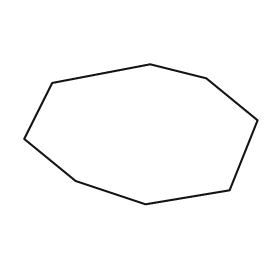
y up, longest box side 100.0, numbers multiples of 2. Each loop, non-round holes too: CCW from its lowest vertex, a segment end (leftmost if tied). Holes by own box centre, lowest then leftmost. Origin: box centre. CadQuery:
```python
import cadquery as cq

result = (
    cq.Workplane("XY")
    .moveTo(2.0, -30.0)
    .lineTo(38.0, -24.0)
    .lineTo(50.0, 6.0)
    .lineTo(28.0, 24.0)
    .lineTo(4.0, 30.0)
    .lineTo(-38.0, 22.0)
    .lineTo(-50.0, -2.0)
    .lineTo(-28.0, -20.0)
    .close()
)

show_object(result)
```